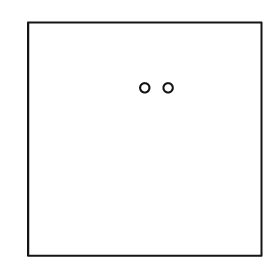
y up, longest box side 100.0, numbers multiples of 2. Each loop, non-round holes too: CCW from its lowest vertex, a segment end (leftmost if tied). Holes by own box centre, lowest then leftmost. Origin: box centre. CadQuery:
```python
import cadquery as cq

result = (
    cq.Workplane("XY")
    .moveTo(-50.0, -50.0)
    .lineTo(50.0, -50.0)
    .lineTo(50.0, 50.0)
    .lineTo(-50.0, 50.0)
    .close()
    .moveTo(0.0, 22.0)
    .circle(2.0)
    .moveTo(10.0, 22.0)
    .circle(2.0)
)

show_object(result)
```